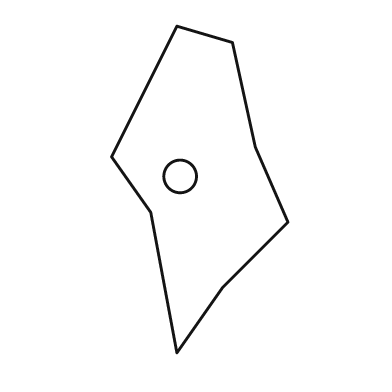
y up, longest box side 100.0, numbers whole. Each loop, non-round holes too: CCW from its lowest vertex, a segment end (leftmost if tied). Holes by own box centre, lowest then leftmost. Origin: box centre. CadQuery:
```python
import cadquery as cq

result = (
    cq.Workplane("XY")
    .moveTo(-7.0, -50.0)
    .lineTo(7.0, -30.0)
    .lineTo(27.0, -10.0)
    .lineTo(17.0, 13.0)
    .lineTo(10.0, 45.0)
    .lineTo(-7.0, 50.0)
    .lineTo(-27.0, 10.0)
    .lineTo(-15.0, -7.0)
    .close()
    .moveTo(-6.0, 4.0)
    .circle(5.0)
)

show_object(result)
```